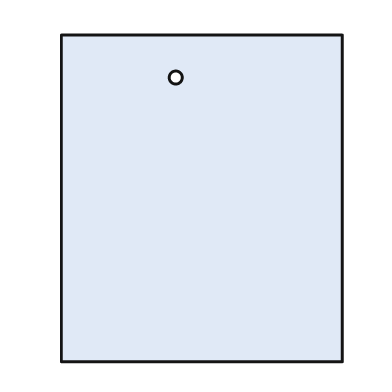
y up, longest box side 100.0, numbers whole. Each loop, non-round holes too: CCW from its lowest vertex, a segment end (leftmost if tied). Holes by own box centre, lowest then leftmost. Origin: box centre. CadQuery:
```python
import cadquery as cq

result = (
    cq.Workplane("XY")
    .moveTo(-43.0, -50.0)
    .lineTo(43.0, -50.0)
    .lineTo(43.0, 50.0)
    .lineTo(-43.0, 50.0)
    .close()
    .moveTo(-8.0, 37.0)
    .circle(2.0)
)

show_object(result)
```